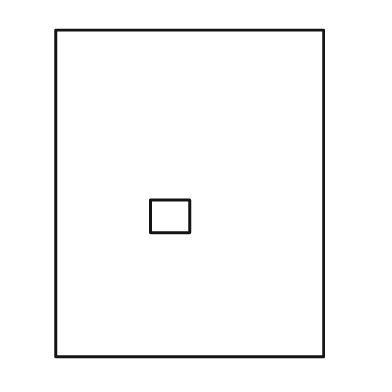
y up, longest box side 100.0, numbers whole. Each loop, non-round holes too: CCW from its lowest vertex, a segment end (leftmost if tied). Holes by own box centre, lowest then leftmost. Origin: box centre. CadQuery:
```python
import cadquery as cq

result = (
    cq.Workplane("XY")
    .moveTo(-41.0, -50.0)
    .lineTo(41.0, -50.0)
    .lineTo(41.0, 50.0)
    .lineTo(-41.0, 50.0)
    .close()
    .moveTo(-12.0, -12.0)
    .lineTo(0.0, -12.0)
    .lineTo(0.0, -2.0)
    .lineTo(-12.0, -2.0)
    .close()
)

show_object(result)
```